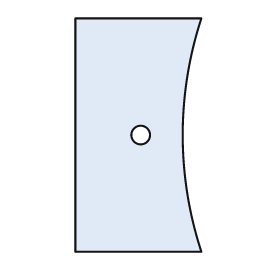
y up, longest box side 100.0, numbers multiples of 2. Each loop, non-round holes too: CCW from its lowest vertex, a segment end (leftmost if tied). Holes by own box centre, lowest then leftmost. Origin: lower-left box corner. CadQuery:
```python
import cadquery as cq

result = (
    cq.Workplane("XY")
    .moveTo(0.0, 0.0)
    .lineTo(54.0, 0.0)
    .threePointArc((46.0, 50.0), (54.0, 100.0))
    .lineTo(0.0, 100.0)
    .close()
    .moveTo(28.0, 50.0)
    .circle(4.0)
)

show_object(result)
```